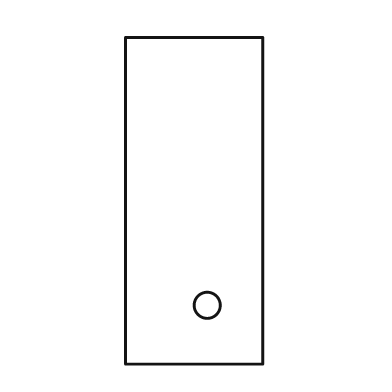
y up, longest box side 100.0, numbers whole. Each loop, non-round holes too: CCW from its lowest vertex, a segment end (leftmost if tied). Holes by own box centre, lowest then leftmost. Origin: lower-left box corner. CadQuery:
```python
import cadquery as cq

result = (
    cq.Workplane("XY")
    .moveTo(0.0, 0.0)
    .lineTo(42.0, 0.0)
    .lineTo(42.0, 100.0)
    .lineTo(0.0, 100.0)
    .close()
    .moveTo(25.0, 18.0)
    .circle(4.0)
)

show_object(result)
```